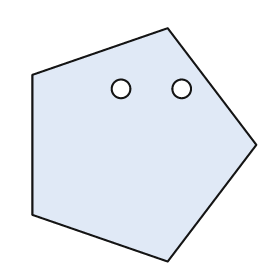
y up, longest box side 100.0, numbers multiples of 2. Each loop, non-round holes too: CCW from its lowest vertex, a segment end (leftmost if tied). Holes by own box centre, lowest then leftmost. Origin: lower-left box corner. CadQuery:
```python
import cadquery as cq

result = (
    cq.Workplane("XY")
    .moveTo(58.0, 0.0)
    .lineTo(96.0, 50.0)
    .lineTo(58.0, 100.0)
    .lineTo(0.0, 80.0)
    .lineTo(0.0, 20.0)
    .close()
    .moveTo(38.0, 74.0)
    .circle(4.0)
    .moveTo(64.0, 74.0)
    .circle(4.0)
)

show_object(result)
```